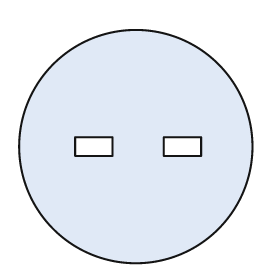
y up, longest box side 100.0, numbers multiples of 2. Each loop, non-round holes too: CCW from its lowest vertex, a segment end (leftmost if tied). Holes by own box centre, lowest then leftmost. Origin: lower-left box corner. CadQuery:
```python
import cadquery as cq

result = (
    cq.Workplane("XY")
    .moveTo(50.0, 50.0)
    .circle(50.0)
    .moveTo(24.0, 46.0)
    .lineTo(40.0, 46.0)
    .lineTo(40.0, 54.0)
    .lineTo(24.0, 54.0)
    .close()
    .moveTo(62.0, 46.0)
    .lineTo(78.0, 46.0)
    .lineTo(78.0, 54.0)
    .lineTo(62.0, 54.0)
    .close()
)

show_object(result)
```